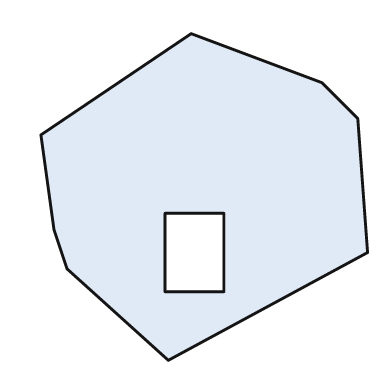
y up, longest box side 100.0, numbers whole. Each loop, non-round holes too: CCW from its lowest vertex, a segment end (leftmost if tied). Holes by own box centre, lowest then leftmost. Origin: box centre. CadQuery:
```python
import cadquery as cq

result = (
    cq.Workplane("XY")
    .moveTo(-11.0, -50.0)
    .lineTo(50.0, -17.0)
    .lineTo(47.0, 24.0)
    .lineTo(36.0, 35.0)
    .lineTo(-4.0, 50.0)
    .lineTo(-50.0, 19.0)
    .lineTo(-46.0, -10.0)
    .lineTo(-42.0, -22.0)
    .close()
    .moveTo(-12.0, -29.0)
    .lineTo(6.0, -29.0)
    .lineTo(6.0, -5.0)
    .lineTo(-12.0, -5.0)
    .close()
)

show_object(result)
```